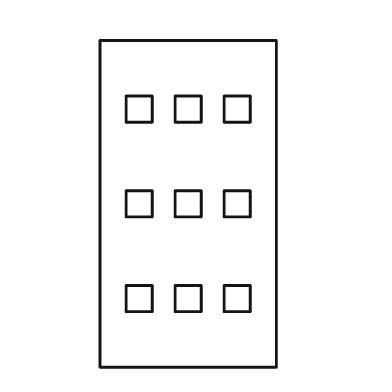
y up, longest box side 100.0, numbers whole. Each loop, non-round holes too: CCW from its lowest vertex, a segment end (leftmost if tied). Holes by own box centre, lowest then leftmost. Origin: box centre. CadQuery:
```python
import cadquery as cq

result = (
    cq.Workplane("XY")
    .moveTo(-27.0, -50.0)
    .lineTo(27.0, -50.0)
    .lineTo(27.0, 50.0)
    .lineTo(-27.0, 50.0)
    .close()
    .moveTo(-19.0, -33.0)
    .lineTo(-11.0, -33.0)
    .lineTo(-11.0, -25.0)
    .lineTo(-19.0, -25.0)
    .close()
    .moveTo(-4.0, -33.0)
    .lineTo(4.0, -33.0)
    .lineTo(4.0, -25.0)
    .lineTo(-4.0, -25.0)
    .close()
    .moveTo(11.0, -33.0)
    .lineTo(19.0, -33.0)
    .lineTo(19.0, -25.0)
    .lineTo(11.0, -25.0)
    .close()
    .moveTo(-19.0, -4.0)
    .lineTo(-11.0, -4.0)
    .lineTo(-11.0, 4.0)
    .lineTo(-19.0, 4.0)
    .close()
    .moveTo(-4.0, -4.0)
    .lineTo(4.0, -4.0)
    .lineTo(4.0, 4.0)
    .lineTo(-4.0, 4.0)
    .close()
    .moveTo(11.0, -4.0)
    .lineTo(19.0, -4.0)
    .lineTo(19.0, 4.0)
    .lineTo(11.0, 4.0)
    .close()
    .moveTo(-19.0, 25.0)
    .lineTo(-11.0, 25.0)
    .lineTo(-11.0, 33.0)
    .lineTo(-19.0, 33.0)
    .close()
    .moveTo(-4.0, 25.0)
    .lineTo(4.0, 25.0)
    .lineTo(4.0, 33.0)
    .lineTo(-4.0, 33.0)
    .close()
    .moveTo(11.0, 25.0)
    .lineTo(19.0, 25.0)
    .lineTo(19.0, 33.0)
    .lineTo(11.0, 33.0)
    .close()
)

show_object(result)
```